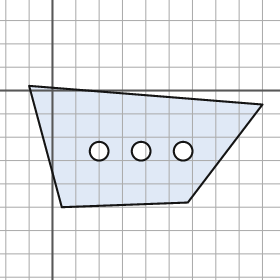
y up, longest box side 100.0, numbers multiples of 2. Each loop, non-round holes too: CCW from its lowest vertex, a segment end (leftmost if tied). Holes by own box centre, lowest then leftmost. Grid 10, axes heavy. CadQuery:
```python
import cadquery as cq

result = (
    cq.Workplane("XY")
    .moveTo(4.0, -50.0)
    .lineTo(58.0, -48.0)
    .lineTo(90.0, -6.0)
    .lineTo(-10.0, 2.0)
    .close()
    .moveTo(20.0, -26.0)
    .circle(4.0)
    .moveTo(38.0, -26.0)
    .circle(4.0)
    .moveTo(56.0, -26.0)
    .circle(4.0)
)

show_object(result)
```